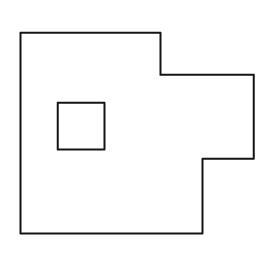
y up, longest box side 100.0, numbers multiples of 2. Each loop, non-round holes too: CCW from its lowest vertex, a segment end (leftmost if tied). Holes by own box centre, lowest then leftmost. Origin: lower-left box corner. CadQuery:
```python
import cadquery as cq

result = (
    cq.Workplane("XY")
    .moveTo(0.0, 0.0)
    .lineTo(78.0, 0.0)
    .lineTo(78.0, 32.0)
    .lineTo(100.0, 32.0)
    .lineTo(100.0, 68.0)
    .lineTo(60.0, 68.0)
    .lineTo(60.0, 86.0)
    .lineTo(0.0, 86.0)
    .close()
    .moveTo(16.0, 36.0)
    .lineTo(36.0, 36.0)
    .lineTo(36.0, 56.0)
    .lineTo(16.0, 56.0)
    .close()
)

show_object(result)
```